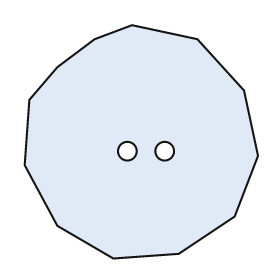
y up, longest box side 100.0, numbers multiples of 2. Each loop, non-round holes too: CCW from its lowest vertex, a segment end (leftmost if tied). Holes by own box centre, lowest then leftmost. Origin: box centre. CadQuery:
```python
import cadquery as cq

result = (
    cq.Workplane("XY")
    .moveTo(-12.0, -50.0)
    .lineTo(16.0, -48.0)
    .lineTo(40.0, -32.0)
    .lineTo(50.0, -6.0)
    .lineTo(44.0, 22.0)
    .lineTo(24.0, 44.0)
    .lineTo(-4.0, 50.0)
    .lineTo(-20.0, 44.0)
    .lineTo(-36.0, 32.0)
    .lineTo(-48.0, 18.0)
    .lineTo(-50.0, -10.0)
    .lineTo(-36.0, -36.0)
    .close()
    .moveTo(-6.0, -4.0)
    .circle(4.0)
    .moveTo(10.0, -4.0)
    .circle(4.0)
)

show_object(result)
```